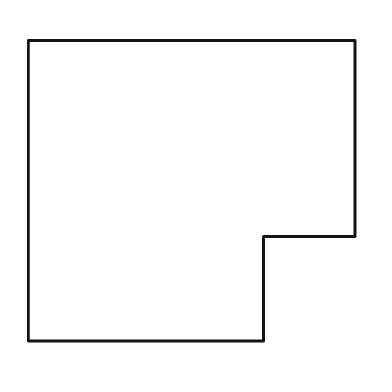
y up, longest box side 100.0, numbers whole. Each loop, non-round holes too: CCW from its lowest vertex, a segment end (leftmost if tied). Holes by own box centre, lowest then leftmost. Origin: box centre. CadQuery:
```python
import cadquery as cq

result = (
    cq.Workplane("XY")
    .moveTo(-50.0, -46.0)
    .lineTo(22.0, -46.0)
    .lineTo(22.0, -14.0)
    .lineTo(50.0, -14.0)
    .lineTo(50.0, 46.0)
    .lineTo(-50.0, 46.0)
    .close()
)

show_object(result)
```